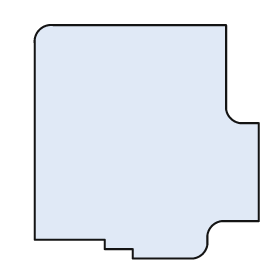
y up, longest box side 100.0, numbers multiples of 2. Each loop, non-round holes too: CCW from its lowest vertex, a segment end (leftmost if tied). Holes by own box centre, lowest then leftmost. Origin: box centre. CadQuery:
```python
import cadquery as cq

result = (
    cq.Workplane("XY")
    .moveTo(-6.0, -50.0)
    .lineTo(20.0, -50.0)
    .threePointArc((24.0, -48.0), (26.0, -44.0))
    .lineTo(26.0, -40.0)
    .threePointArc((28.0, -36.0), (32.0, -34.0))
    .lineTo(48.0, -34.0)
    .lineTo(48.0, 8.0)
    .lineTo(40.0, 8.0)
    .threePointArc((36.0, 10.0), (34.0, 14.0))
    .lineTo(34.0, 50.0)
    .lineTo(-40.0, 50.0)
    .threePointArc((-46.0, 48.0), (-48.0, 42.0))
    .lineTo(-48.0, -42.0)
    .lineTo(-18.0, -42.0)
    .lineTo(-18.0, -46.0)
    .lineTo(-6.0, -46.0)
    .close()
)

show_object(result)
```